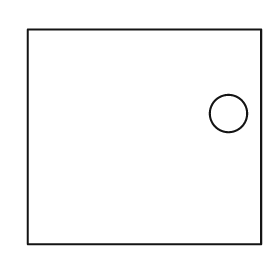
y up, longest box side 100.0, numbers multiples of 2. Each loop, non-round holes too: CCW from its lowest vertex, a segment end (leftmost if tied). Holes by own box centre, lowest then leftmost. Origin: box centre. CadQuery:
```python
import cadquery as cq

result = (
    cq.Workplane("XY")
    .moveTo(-50.0, -46.0)
    .lineTo(50.0, -46.0)
    .lineTo(50.0, 46.0)
    .lineTo(-50.0, 46.0)
    .close()
    .moveTo(36.0, 10.0)
    .circle(8.0)
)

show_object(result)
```